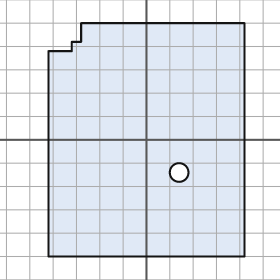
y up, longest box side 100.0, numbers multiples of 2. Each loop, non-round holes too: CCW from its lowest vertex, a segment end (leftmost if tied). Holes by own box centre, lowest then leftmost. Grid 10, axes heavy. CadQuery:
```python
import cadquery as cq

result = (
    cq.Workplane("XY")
    .moveTo(-42.0, -50.0)
    .lineTo(42.0, -50.0)
    .lineTo(42.0, 50.0)
    .lineTo(-28.0, 50.0)
    .lineTo(-28.0, 42.0)
    .lineTo(-32.0, 42.0)
    .lineTo(-32.0, 38.0)
    .lineTo(-42.0, 38.0)
    .close()
    .moveTo(14.0, -14.0)
    .circle(4.0)
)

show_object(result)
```